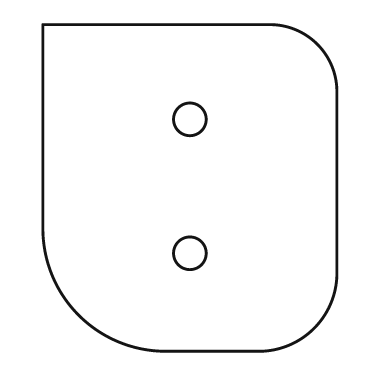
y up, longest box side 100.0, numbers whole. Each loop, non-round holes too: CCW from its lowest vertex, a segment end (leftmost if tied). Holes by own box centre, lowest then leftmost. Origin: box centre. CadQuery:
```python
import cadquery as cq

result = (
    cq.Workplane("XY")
    .moveTo(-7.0, -50.0)
    .lineTo(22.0, -50.0)
    .threePointArc((38.0, -43.0), (45.0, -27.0))
    .lineTo(45.0, 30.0)
    .threePointArc((39.0, 44.0), (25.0, 50.0))
    .lineTo(-45.0, 50.0)
    .lineTo(-45.0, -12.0)
    .threePointArc((-34.0, -39.0), (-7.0, -50.0))
    .close()
    .moveTo(0.0, -20.0)
    .circle(5.0)
    .moveTo(0.0, 21.0)
    .circle(5.0)
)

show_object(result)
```